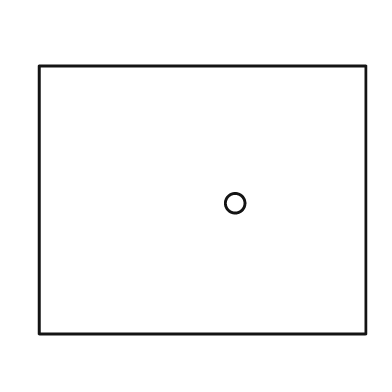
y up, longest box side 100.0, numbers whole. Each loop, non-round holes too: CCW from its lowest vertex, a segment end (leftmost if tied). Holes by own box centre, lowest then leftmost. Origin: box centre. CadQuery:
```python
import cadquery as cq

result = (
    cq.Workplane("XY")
    .moveTo(-50.0, -41.0)
    .lineTo(50.0, -41.0)
    .lineTo(50.0, 41.0)
    .lineTo(-50.0, 41.0)
    .close()
    .moveTo(10.0, -1.0)
    .circle(3.0)
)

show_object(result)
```